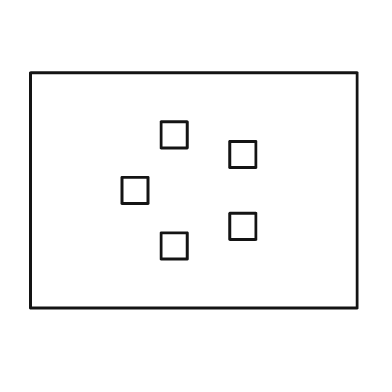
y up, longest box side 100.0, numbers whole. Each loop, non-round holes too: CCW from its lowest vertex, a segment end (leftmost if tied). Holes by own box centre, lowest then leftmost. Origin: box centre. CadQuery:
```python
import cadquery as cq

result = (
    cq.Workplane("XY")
    .moveTo(-50.0, -36.0)
    .lineTo(50.0, -36.0)
    .lineTo(50.0, 36.0)
    .lineTo(-50.0, 36.0)
    .close()
    .moveTo(-10.0, -21.0)
    .lineTo(-2.0, -21.0)
    .lineTo(-2.0, -13.0)
    .lineTo(-10.0, -13.0)
    .close()
    .moveTo(11.0, -15.0)
    .lineTo(19.0, -15.0)
    .lineTo(19.0, -7.0)
    .lineTo(11.0, -7.0)
    .close()
    .moveTo(-22.0, -4.0)
    .lineTo(-14.0, -4.0)
    .lineTo(-14.0, 4.0)
    .lineTo(-22.0, 4.0)
    .close()
    .moveTo(11.0, 7.0)
    .lineTo(19.0, 7.0)
    .lineTo(19.0, 15.0)
    .lineTo(11.0, 15.0)
    .close()
    .moveTo(-10.0, 13.0)
    .lineTo(-2.0, 13.0)
    .lineTo(-2.0, 21.0)
    .lineTo(-10.0, 21.0)
    .close()
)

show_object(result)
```